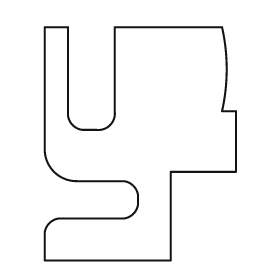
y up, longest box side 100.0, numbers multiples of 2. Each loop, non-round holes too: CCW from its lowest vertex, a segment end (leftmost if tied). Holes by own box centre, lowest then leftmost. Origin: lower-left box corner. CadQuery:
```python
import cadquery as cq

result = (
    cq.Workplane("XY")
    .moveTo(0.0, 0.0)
    .lineTo(54.0, 0.0)
    .lineTo(54.0, 38.0)
    .lineTo(82.0, 38.0)
    .lineTo(82.0, 64.0)
    .lineTo(76.0, 64.0)
    .threePointArc((78.0, 82.0), (76.0, 100.0))
    .lineTo(30.0, 100.0)
    .lineTo(30.0, 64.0)
    .threePointArc((28.0, 58.0), (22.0, 56.0))
    .lineTo(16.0, 56.0)
    .threePointArc((12.0, 58.0), (10.0, 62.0))
    .lineTo(10.0, 100.0)
    .lineTo(0.0, 100.0)
    .lineTo(0.0, 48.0)
    .threePointArc((4.0, 38.0), (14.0, 34.0))
    .lineTo(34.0, 34.0)
    .threePointArc((38.0, 32.0), (40.0, 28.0))
    .lineTo(40.0, 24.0)
    .threePointArc((38.0, 20.0), (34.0, 18.0))
    .lineTo(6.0, 18.0)
    .threePointArc((2.0, 16.0), (0.0, 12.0))
    .close()
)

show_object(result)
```